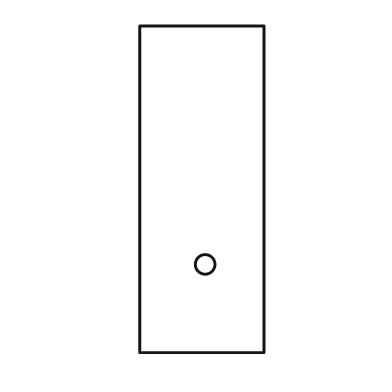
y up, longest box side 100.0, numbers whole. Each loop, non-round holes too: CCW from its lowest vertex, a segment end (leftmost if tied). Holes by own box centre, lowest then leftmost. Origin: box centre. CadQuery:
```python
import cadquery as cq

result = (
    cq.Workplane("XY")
    .moveTo(-19.0, -50.0)
    .lineTo(19.0, -50.0)
    .lineTo(19.0, 50.0)
    .lineTo(-19.0, 50.0)
    .close()
    .moveTo(1.0, -23.0)
    .circle(3.0)
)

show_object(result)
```